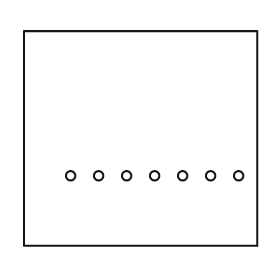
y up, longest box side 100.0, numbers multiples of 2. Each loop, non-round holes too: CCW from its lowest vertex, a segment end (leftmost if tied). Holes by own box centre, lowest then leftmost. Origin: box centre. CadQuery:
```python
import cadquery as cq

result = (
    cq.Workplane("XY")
    .moveTo(-50.0, -46.0)
    .lineTo(50.0, -46.0)
    .lineTo(50.0, 46.0)
    .lineTo(-50.0, 46.0)
    .close()
    .moveTo(-30.0, -16.0)
    .circle(2.0)
    .moveTo(-18.0, -16.0)
    .circle(2.0)
    .moveTo(-6.0, -16.0)
    .circle(2.0)
    .moveTo(6.0, -16.0)
    .circle(2.0)
    .moveTo(18.0, -16.0)
    .circle(2.0)
    .moveTo(30.0, -16.0)
    .circle(2.0)
    .moveTo(42.0, -16.0)
    .circle(2.0)
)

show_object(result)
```